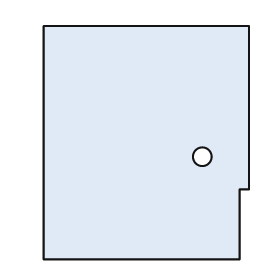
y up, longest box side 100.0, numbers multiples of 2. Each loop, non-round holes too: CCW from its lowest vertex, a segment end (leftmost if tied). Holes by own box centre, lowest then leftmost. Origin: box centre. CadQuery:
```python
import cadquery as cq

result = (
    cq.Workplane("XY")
    .moveTo(-44.0, -50.0)
    .lineTo(40.0, -50.0)
    .lineTo(40.0, -20.0)
    .lineTo(44.0, -20.0)
    .lineTo(44.0, 50.0)
    .lineTo(-44.0, 50.0)
    .close()
    .moveTo(24.0, -6.0)
    .circle(4.0)
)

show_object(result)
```